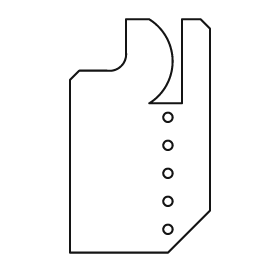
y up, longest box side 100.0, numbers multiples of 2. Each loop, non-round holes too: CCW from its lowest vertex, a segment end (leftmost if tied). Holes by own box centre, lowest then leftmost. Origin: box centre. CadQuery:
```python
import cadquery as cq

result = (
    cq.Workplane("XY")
    .moveTo(-30.0, -50.0)
    .lineTo(12.0, -50.0)
    .lineTo(30.0, -32.0)
    .lineTo(30.0, 46.0)
    .lineTo(26.0, 50.0)
    .lineTo(18.0, 50.0)
    .lineTo(18.0, 14.0)
    .lineTo(4.0, 14.0)
    .threePointArc((14.0, 32.0), (4.0, 50.0))
    .lineTo(-6.0, 50.0)
    .lineTo(-6.0, 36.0)
    .threePointArc((-8.0, 30.0), (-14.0, 28.0))
    .lineTo(-26.0, 28.0)
    .lineTo(-30.0, 24.0)
    .close()
    .moveTo(12.0, -40.0)
    .circle(2.0)
    .moveTo(12.0, -28.0)
    .circle(2.0)
    .moveTo(12.0, -16.0)
    .circle(2.0)
    .moveTo(12.0, -4.0)
    .circle(2.0)
    .moveTo(12.0, 8.0)
    .circle(2.0)
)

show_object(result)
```